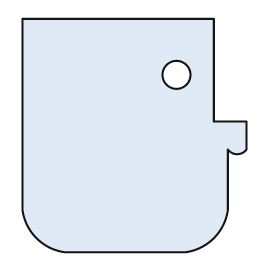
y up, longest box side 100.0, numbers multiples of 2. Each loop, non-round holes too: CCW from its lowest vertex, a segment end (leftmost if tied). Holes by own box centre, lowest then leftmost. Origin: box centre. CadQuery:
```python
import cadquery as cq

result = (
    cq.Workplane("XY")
    .moveTo(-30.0, -50.0)
    .lineTo(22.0, -50.0)
    .threePointArc((34.0, -44.0), (40.0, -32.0))
    .lineTo(40.0, -6.0)
    .threePointArc((44.0, -8.0), (48.0, -6.0))
    .lineTo(48.0, 6.0)
    .lineTo(34.0, 6.0)
    .lineTo(34.0, 50.0)
    .lineTo(-48.0, 50.0)
    .lineTo(-48.0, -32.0)
    .threePointArc((-42.0, -44.0), (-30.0, -50.0))
    .close()
    .moveTo(18.0, 26.0)
    .circle(6.0)
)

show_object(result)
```